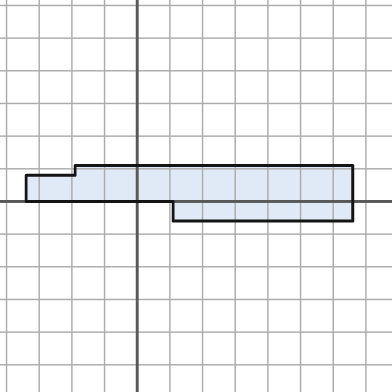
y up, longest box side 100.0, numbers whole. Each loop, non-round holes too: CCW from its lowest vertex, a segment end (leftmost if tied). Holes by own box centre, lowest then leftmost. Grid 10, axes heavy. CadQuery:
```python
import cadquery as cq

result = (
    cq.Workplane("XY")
    .moveTo(11.0, -6.0)
    .lineTo(66.0, -6.0)
    .lineTo(66.0, 11.0)
    .lineTo(-19.0, 11.0)
    .lineTo(-19.0, 8.0)
    .lineTo(-34.0, 8.0)
    .lineTo(-34.0, 0.0)
    .lineTo(11.0, 0.0)
    .close()
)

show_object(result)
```